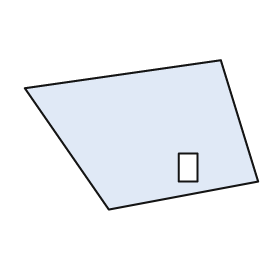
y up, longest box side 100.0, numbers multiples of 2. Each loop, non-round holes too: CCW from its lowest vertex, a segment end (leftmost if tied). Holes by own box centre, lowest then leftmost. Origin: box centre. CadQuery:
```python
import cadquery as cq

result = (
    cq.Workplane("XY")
    .moveTo(-14.0, -32.0)
    .lineTo(50.0, -20.0)
    .lineTo(34.0, 32.0)
    .lineTo(-50.0, 20.0)
    .close()
    .moveTo(16.0, -20.0)
    .lineTo(24.0, -20.0)
    .lineTo(24.0, -8.0)
    .lineTo(16.0, -8.0)
    .close()
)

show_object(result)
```